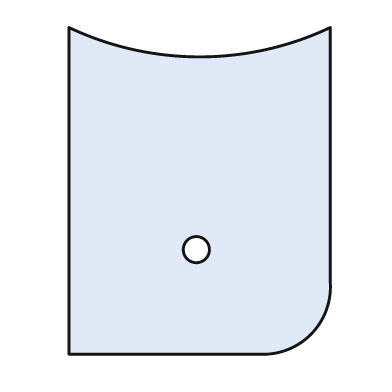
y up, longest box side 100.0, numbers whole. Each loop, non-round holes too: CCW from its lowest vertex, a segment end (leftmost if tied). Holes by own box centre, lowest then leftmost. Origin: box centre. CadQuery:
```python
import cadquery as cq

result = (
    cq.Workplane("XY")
    .moveTo(-40.0, -50.0)
    .lineTo(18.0, -50.0)
    .threePointArc((34.0, -44.0), (40.0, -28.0))
    .lineTo(40.0, 50.0)
    .threePointArc((0.0, 41.0), (-40.0, 50.0))
    .close()
    .moveTo(-1.0, -18.0)
    .circle(4.0)
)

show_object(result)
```